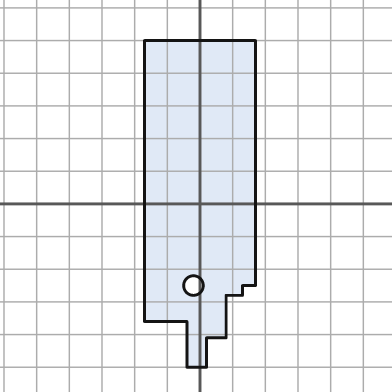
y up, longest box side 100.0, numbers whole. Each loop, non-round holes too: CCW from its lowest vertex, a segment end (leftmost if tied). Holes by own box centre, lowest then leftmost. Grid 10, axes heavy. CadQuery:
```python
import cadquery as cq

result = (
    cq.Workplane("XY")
    .moveTo(-4.0, -50.0)
    .lineTo(2.0, -50.0)
    .lineTo(2.0, -41.0)
    .lineTo(8.0, -41.0)
    .lineTo(8.0, -28.0)
    .lineTo(13.0, -28.0)
    .lineTo(13.0, -25.0)
    .lineTo(17.0, -25.0)
    .lineTo(17.0, 50.0)
    .lineTo(-17.0, 50.0)
    .lineTo(-17.0, -36.0)
    .lineTo(-4.0, -36.0)
    .close()
    .moveTo(-2.0, -25.0)
    .circle(3.0)
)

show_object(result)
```